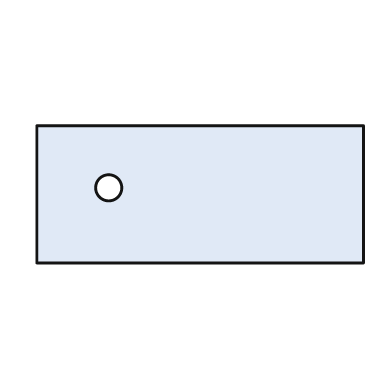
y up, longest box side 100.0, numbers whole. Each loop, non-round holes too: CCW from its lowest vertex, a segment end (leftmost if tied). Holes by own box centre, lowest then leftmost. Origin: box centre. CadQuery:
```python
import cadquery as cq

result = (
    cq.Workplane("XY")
    .moveTo(-50.0, -21.0)
    .lineTo(50.0, -21.0)
    .lineTo(50.0, 21.0)
    .lineTo(-50.0, 21.0)
    .close()
    .moveTo(-28.0, 2.0)
    .circle(4.0)
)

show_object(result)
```